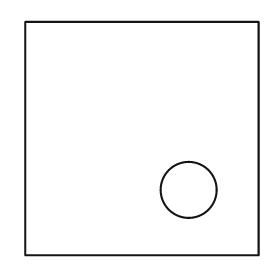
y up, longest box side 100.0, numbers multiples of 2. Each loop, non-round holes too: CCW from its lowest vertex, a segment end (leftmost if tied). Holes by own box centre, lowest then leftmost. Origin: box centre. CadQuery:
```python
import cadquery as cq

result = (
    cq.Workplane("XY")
    .moveTo(-50.0, -50.0)
    .lineTo(50.0, -50.0)
    .lineTo(50.0, 50.0)
    .lineTo(-50.0, 50.0)
    .close()
    .moveTo(20.0, -22.0)
    .circle(12.0)
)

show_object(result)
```